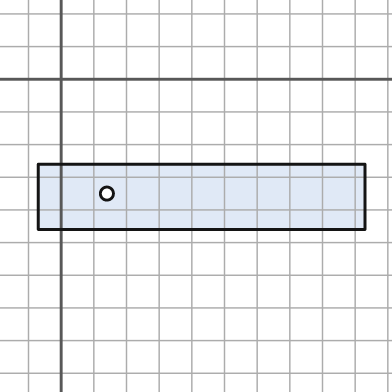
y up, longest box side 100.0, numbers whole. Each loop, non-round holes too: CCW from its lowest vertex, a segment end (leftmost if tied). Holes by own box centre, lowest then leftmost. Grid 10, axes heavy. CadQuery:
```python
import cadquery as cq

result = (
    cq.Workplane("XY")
    .moveTo(-7.0, -46.0)
    .lineTo(93.0, -46.0)
    .lineTo(93.0, -26.0)
    .lineTo(-7.0, -26.0)
    .close()
    .moveTo(14.0, -35.0)
    .circle(2.0)
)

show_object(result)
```